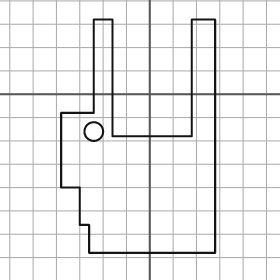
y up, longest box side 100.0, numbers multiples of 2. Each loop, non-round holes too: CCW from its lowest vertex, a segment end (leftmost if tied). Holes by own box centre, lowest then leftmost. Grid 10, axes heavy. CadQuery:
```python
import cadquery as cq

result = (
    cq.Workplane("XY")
    .moveTo(-26.0, -68.0)
    .lineTo(28.0, -68.0)
    .lineTo(28.0, 32.0)
    .lineTo(18.0, 32.0)
    .lineTo(18.0, -18.0)
    .lineTo(-16.0, -18.0)
    .lineTo(-16.0, 32.0)
    .lineTo(-24.0, 32.0)
    .lineTo(-24.0, -8.0)
    .lineTo(-38.0, -8.0)
    .lineTo(-38.0, -40.0)
    .lineTo(-30.0, -40.0)
    .lineTo(-30.0, -56.0)
    .lineTo(-26.0, -56.0)
    .close()
    .moveTo(-24.0, -16.0)
    .circle(4.0)
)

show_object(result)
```